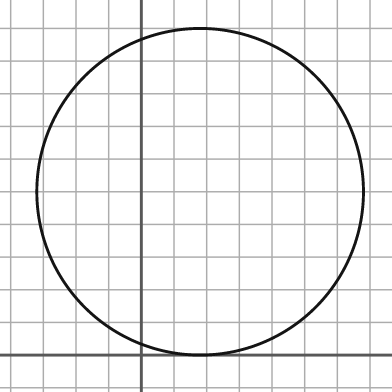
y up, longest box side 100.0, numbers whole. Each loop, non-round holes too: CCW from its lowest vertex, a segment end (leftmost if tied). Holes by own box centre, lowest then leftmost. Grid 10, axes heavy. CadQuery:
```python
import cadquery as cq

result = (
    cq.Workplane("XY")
    .moveTo(18.0, 50.0)
    .circle(50.0)
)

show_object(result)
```